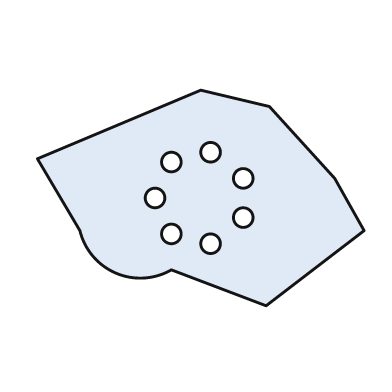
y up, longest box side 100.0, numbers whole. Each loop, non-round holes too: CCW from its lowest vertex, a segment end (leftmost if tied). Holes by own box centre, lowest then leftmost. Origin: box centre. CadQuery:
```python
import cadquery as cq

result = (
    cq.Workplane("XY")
    .moveTo(20.0, -33.0)
    .lineTo(50.0, -10.0)
    .lineTo(41.0, 6.0)
    .lineTo(21.0, 28.0)
    .lineTo(0.0, 33.0)
    .lineTo(-50.0, 12.0)
    .lineTo(-37.0, -10.0)
    .threePointArc((-26.0, -23.0), (-9.0, -22.0))
    .close()
    .moveTo(3.0, -14.0)
    .circle(3.0)
    .moveTo(-9.0, -11.0)
    .circle(3.0)
    .moveTo(13.0, -6.0)
    .circle(3.0)
    .moveTo(-14.0, 0.0)
    .circle(3.0)
    .moveTo(13.0, 6.0)
    .circle(3.0)
    .moveTo(-9.0, 11.0)
    .circle(3.0)
    .moveTo(3.0, 14.0)
    .circle(3.0)
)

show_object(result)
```